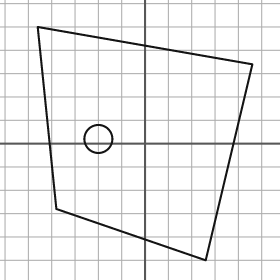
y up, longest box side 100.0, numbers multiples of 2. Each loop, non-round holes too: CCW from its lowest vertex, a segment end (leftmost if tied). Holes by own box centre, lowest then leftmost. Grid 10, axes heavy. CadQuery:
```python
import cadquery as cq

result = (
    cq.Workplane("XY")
    .moveTo(26.0, -50.0)
    .lineTo(46.0, 34.0)
    .lineTo(-46.0, 50.0)
    .lineTo(-38.0, -28.0)
    .close()
    .moveTo(-20.0, 2.0)
    .circle(6.0)
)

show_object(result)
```